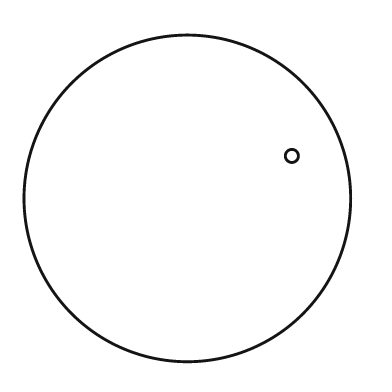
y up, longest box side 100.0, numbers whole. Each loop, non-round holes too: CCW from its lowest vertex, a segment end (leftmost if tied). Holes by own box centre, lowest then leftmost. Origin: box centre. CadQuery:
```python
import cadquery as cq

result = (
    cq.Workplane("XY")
    .moveTo(0.0, 0.0)
    .circle(50.0)
    .moveTo(32.0, 13.0)
    .circle(2.0)
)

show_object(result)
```